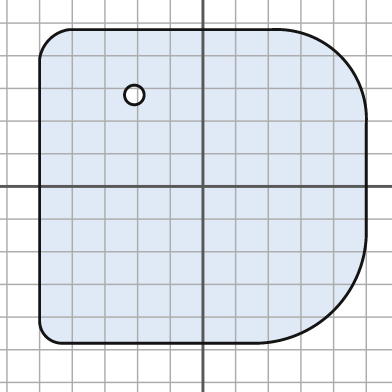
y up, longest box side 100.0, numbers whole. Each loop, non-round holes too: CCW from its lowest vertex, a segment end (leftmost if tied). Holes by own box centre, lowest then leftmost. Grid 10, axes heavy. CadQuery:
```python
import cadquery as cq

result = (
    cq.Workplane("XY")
    .moveTo(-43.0, -48.0)
    .lineTo(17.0, -48.0)
    .threePointArc((40.0, -38.0), (50.0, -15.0))
    .lineTo(50.0, 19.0)
    .threePointArc((42.0, 40.0), (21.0, 48.0))
    .lineTo(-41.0, 48.0)
    .threePointArc((-47.0, 45.0), (-50.0, 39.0))
    .lineTo(-50.0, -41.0)
    .threePointArc((-48.0, -46.0), (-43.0, -48.0))
    .close()
    .moveTo(-21.0, 28.0)
    .circle(3.0)
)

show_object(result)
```